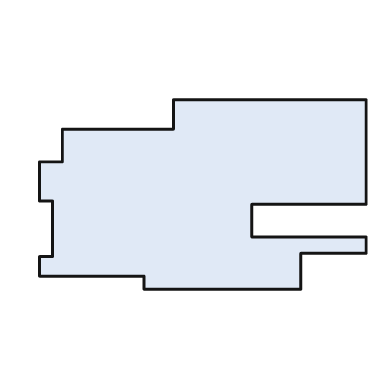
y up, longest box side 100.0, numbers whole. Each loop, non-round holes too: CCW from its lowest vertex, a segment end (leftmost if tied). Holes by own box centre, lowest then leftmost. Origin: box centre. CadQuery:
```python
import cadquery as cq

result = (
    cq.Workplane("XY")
    .moveTo(-18.0, -29.0)
    .lineTo(30.0, -29.0)
    .lineTo(30.0, -18.0)
    .lineTo(50.0, -18.0)
    .lineTo(50.0, -13.0)
    .lineTo(15.0, -13.0)
    .lineTo(15.0, -3.0)
    .lineTo(50.0, -3.0)
    .lineTo(50.0, 29.0)
    .lineTo(-9.0, 29.0)
    .lineTo(-9.0, 20.0)
    .lineTo(-43.0, 20.0)
    .lineTo(-43.0, 10.0)
    .lineTo(-50.0, 10.0)
    .lineTo(-50.0, -2.0)
    .lineTo(-46.0, -2.0)
    .lineTo(-46.0, -19.0)
    .lineTo(-50.0, -19.0)
    .lineTo(-50.0, -25.0)
    .lineTo(-18.0, -25.0)
    .close()
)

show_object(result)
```